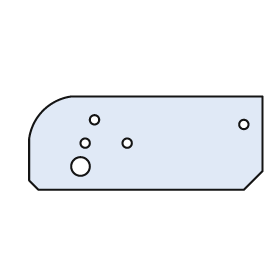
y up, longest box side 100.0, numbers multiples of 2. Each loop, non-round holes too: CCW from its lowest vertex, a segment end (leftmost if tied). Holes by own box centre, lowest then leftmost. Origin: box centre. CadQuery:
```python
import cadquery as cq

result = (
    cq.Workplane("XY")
    .moveTo(-46.0, -20.0)
    .lineTo(42.0, -20.0)
    .lineTo(50.0, -12.0)
    .lineTo(50.0, 20.0)
    .lineTo(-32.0, 20.0)
    .threePointArc((-44.0, 14.0), (-50.0, 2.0))
    .lineTo(-50.0, -16.0)
    .close()
    .moveTo(-28.0, -10.0)
    .circle(4.0)
    .moveTo(-26.0, 0.0)
    .circle(2.0)
    .moveTo(-8.0, 0.0)
    .circle(2.0)
    .moveTo(42.0, 8.0)
    .circle(2.0)
    .moveTo(-22.0, 10.0)
    .circle(2.0)
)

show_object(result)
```